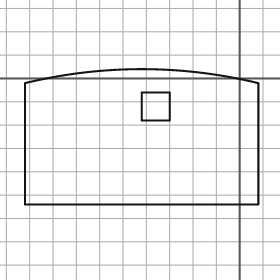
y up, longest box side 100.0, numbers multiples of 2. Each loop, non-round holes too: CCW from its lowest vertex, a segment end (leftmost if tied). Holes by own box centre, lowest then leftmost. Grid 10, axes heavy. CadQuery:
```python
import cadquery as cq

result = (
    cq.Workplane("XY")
    .moveTo(-92.0, -54.0)
    .lineTo(8.0, -54.0)
    .lineTo(8.0, -2.0)
    .threePointArc((-42.0, 4.0), (-92.0, -2.0))
    .close()
    .moveTo(-42.0, -18.0)
    .lineTo(-30.0, -18.0)
    .lineTo(-30.0, -6.0)
    .lineTo(-42.0, -6.0)
    .close()
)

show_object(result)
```